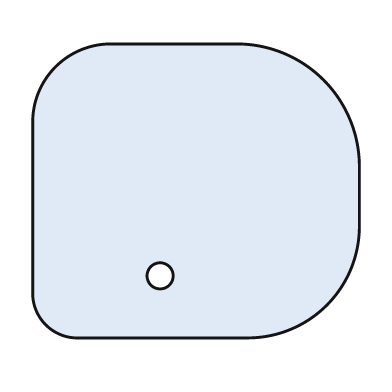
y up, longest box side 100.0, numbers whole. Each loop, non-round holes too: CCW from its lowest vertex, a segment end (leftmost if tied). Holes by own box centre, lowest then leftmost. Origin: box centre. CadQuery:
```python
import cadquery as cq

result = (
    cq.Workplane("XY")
    .moveTo(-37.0, -45.0)
    .lineTo(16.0, -45.0)
    .threePointArc((40.0, -35.0), (50.0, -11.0))
    .lineTo(50.0, 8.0)
    .threePointArc((39.0, 34.0), (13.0, 45.0))
    .lineTo(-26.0, 45.0)
    .threePointArc((-43.0, 38.0), (-50.0, 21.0))
    .lineTo(-50.0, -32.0)
    .threePointArc((-46.0, -41.0), (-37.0, -45.0))
    .close()
    .moveTo(-11.0, -26.0)
    .circle(4.0)
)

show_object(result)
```